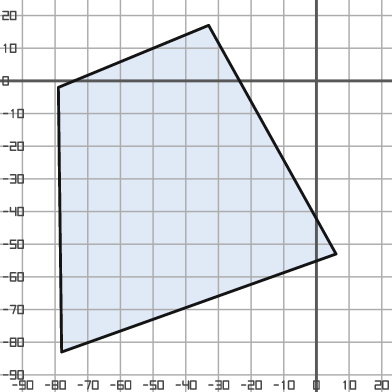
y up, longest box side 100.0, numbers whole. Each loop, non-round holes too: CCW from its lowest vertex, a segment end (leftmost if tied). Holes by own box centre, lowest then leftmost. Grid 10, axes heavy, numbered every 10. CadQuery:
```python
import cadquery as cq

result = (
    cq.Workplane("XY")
    .moveTo(-78.0, -83.0)
    .lineTo(6.0, -53.0)
    .lineTo(-33.0, 17.0)
    .lineTo(-79.0, -2.0)
    .close()
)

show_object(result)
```